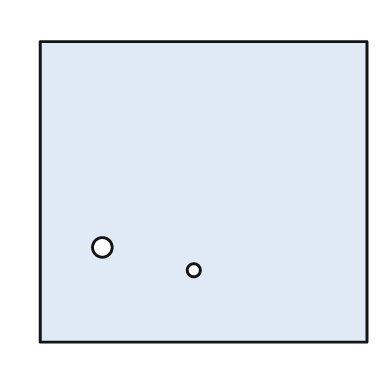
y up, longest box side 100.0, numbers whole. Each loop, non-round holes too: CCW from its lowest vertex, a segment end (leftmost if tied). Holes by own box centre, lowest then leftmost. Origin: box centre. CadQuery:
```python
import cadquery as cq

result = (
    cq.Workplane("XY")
    .moveTo(-50.0, -46.0)
    .lineTo(50.0, -46.0)
    .lineTo(50.0, 46.0)
    .lineTo(-50.0, 46.0)
    .close()
    .moveTo(-3.0, -24.0)
    .circle(2.0)
    .moveTo(-31.0, -17.0)
    .circle(3.0)
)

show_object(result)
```